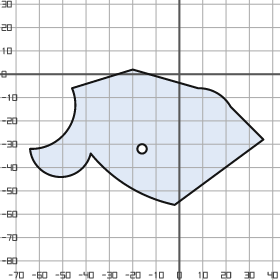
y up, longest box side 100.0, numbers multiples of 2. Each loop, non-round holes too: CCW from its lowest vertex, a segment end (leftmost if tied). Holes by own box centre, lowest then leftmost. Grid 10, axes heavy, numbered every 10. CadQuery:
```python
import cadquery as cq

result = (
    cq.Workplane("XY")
    .moveTo(-2.0, -56.0)
    .lineTo(36.0, -28.0)
    .lineTo(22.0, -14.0)
    .threePointArc((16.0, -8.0), (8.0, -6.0))
    .lineTo(-20.0, 2.0)
    .lineTo(-46.0, -6.0)
    .threePointArc((-48.0, -24.0), (-64.0, -32.0))
    .threePointArc((-52.0, -44.0), (-38.0, -34.0))
    .threePointArc((-22.0, -48.0), (-2.0, -56.0))
    .close()
    .moveTo(-16.0, -32.0)
    .circle(2.0)
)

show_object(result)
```